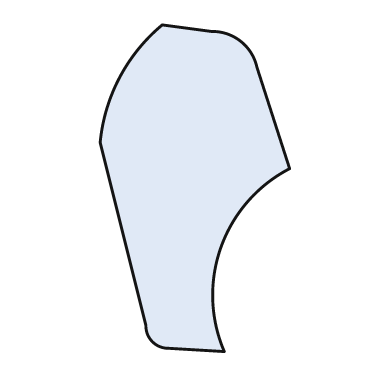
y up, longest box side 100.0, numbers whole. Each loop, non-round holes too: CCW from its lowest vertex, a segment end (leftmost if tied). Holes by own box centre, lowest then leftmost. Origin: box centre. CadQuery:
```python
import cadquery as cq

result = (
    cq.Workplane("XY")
    .moveTo(9.0, -50.0)
    .threePointArc((8.0, -18.0), (29.0, 6.0))
    .lineTo(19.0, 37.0)
    .threePointArc((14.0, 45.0), (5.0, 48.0))
    .lineTo(-10.0, 50.0)
    .threePointArc((-23.0, 34.0), (-29.0, 14.0))
    .lineTo(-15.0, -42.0)
    .threePointArc((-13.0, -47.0), (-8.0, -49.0))
    .close()
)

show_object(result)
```